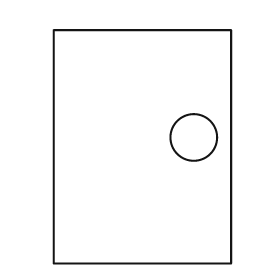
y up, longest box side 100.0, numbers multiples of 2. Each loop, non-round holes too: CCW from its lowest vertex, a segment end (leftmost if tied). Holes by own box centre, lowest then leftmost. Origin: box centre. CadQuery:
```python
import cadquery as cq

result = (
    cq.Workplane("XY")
    .moveTo(-38.0, -50.0)
    .lineTo(38.0, -50.0)
    .lineTo(38.0, 50.0)
    .lineTo(-38.0, 50.0)
    .close()
    .moveTo(22.0, 4.0)
    .circle(10.0)
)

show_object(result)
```